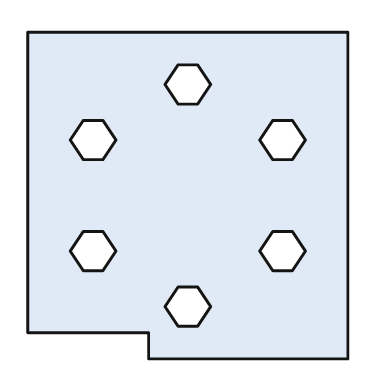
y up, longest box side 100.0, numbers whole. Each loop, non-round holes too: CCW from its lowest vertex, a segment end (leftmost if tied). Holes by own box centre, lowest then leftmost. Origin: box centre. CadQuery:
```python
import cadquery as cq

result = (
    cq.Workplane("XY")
    .moveTo(-12.0, -50.0)
    .lineTo(49.0, -50.0)
    .lineTo(49.0, 50.0)
    .lineTo(-49.0, 50.0)
    .lineTo(-49.0, -42.0)
    .lineTo(-12.0, -42.0)
    .close()
    .moveTo(-3.0, -40.0)
    .lineTo(3.0, -40.0)
    .lineTo(7.0, -34.0)
    .lineTo(3.0, -28.0)
    .lineTo(-3.0, -28.0)
    .lineTo(-7.0, -34.0)
    .close()
    .moveTo(-32.0, -23.0)
    .lineTo(-26.0, -23.0)
    .lineTo(-22.0, -17.0)
    .lineTo(-26.0, -11.0)
    .lineTo(-32.0, -11.0)
    .lineTo(-36.0, -17.0)
    .close()
    .moveTo(26.0, -23.0)
    .lineTo(32.0, -23.0)
    .lineTo(36.0, -17.0)
    .lineTo(32.0, -11.0)
    .lineTo(26.0, -11.0)
    .lineTo(22.0, -17.0)
    .close()
    .moveTo(-32.0, 11.0)
    .lineTo(-26.0, 11.0)
    .lineTo(-22.0, 17.0)
    .lineTo(-26.0, 23.0)
    .lineTo(-32.0, 23.0)
    .lineTo(-36.0, 17.0)
    .close()
    .moveTo(26.0, 11.0)
    .lineTo(32.0, 11.0)
    .lineTo(36.0, 17.0)
    .lineTo(32.0, 23.0)
    .lineTo(26.0, 23.0)
    .lineTo(22.0, 17.0)
    .close()
    .moveTo(-3.0, 28.0)
    .lineTo(3.0, 28.0)
    .lineTo(7.0, 34.0)
    .lineTo(3.0, 40.0)
    .lineTo(-3.0, 40.0)
    .lineTo(-7.0, 34.0)
    .close()
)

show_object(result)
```